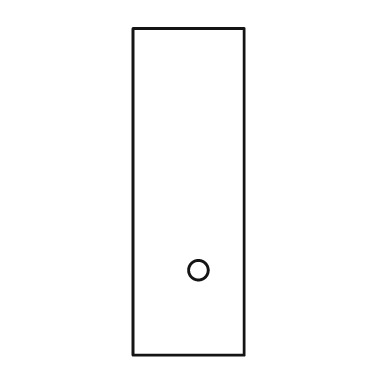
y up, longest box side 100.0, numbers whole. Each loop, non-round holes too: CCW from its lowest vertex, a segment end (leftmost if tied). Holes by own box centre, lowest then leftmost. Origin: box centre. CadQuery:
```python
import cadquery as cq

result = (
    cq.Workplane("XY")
    .moveTo(-17.0, -50.0)
    .lineTo(17.0, -50.0)
    .lineTo(17.0, 50.0)
    .lineTo(-17.0, 50.0)
    .close()
    .moveTo(3.0, -24.0)
    .circle(3.0)
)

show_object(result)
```